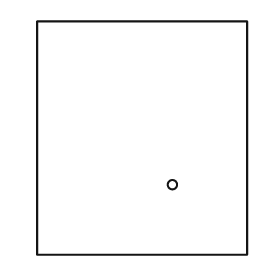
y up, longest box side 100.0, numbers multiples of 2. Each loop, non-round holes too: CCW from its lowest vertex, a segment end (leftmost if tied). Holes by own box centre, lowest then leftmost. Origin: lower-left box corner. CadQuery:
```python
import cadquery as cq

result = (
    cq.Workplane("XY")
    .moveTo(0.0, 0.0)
    .lineTo(90.0, 0.0)
    .lineTo(90.0, 100.0)
    .lineTo(0.0, 100.0)
    .close()
    .moveTo(58.0, 30.0)
    .circle(2.0)
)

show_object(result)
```